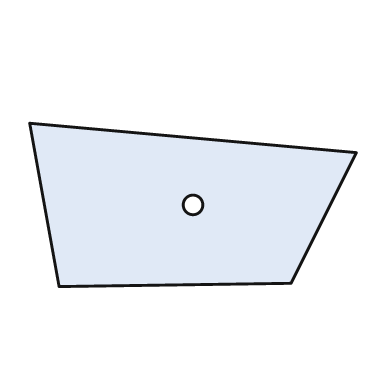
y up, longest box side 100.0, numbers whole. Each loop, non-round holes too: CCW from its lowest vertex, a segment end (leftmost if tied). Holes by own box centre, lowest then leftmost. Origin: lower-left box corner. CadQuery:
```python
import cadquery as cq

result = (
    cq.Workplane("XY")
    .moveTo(9.0, 0.0)
    .lineTo(80.0, 1.0)
    .lineTo(100.0, 41.0)
    .lineTo(0.0, 50.0)
    .close()
    .moveTo(50.0, 25.0)
    .circle(3.0)
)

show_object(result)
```